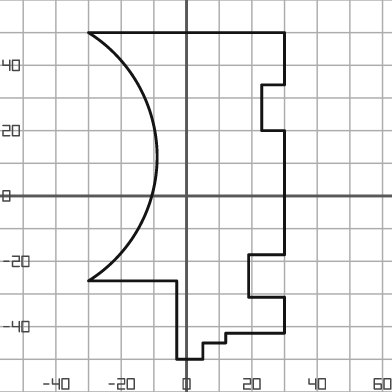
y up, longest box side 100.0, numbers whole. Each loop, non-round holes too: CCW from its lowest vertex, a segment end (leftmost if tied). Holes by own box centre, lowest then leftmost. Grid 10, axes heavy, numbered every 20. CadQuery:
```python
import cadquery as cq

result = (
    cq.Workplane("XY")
    .moveTo(-3.0, -50.0)
    .lineTo(5.0, -50.0)
    .lineTo(5.0, -45.0)
    .lineTo(12.0, -45.0)
    .lineTo(12.0, -42.0)
    .lineTo(30.0, -42.0)
    .lineTo(30.0, -31.0)
    .lineTo(19.0, -31.0)
    .lineTo(19.0, -18.0)
    .lineTo(30.0, -18.0)
    .lineTo(30.0, 20.0)
    .lineTo(23.0, 20.0)
    .lineTo(23.0, 34.0)
    .lineTo(30.0, 34.0)
    .lineTo(30.0, 50.0)
    .lineTo(-30.0, 50.0)
    .threePointArc((-9.0, 12.0), (-30.0, -26.0))
    .lineTo(-3.0, -26.0)
    .close()
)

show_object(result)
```